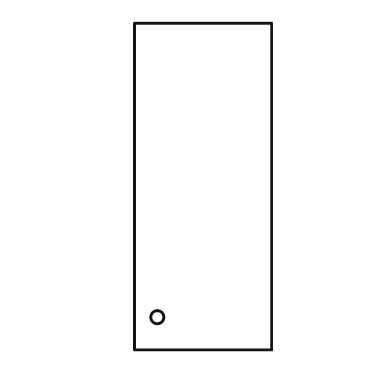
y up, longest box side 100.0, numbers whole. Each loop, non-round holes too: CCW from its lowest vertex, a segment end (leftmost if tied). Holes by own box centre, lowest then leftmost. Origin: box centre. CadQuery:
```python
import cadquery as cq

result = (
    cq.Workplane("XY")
    .moveTo(-21.0, -50.0)
    .lineTo(21.0, -50.0)
    .lineTo(21.0, 50.0)
    .lineTo(-21.0, 50.0)
    .close()
    .moveTo(-14.0, -40.0)
    .circle(2.0)
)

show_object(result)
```